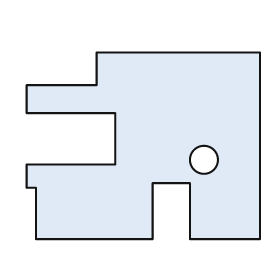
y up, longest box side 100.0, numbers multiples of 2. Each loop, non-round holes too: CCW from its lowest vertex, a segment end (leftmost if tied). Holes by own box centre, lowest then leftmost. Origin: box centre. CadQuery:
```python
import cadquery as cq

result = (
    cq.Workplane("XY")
    .moveTo(-46.0, -40.0)
    .lineTo(4.0, -40.0)
    .lineTo(4.0, -16.0)
    .lineTo(20.0, -16.0)
    .lineTo(20.0, -40.0)
    .lineTo(50.0, -40.0)
    .lineTo(50.0, 40.0)
    .lineTo(-20.0, 40.0)
    .lineTo(-20.0, 26.0)
    .lineTo(-50.0, 26.0)
    .lineTo(-50.0, 14.0)
    .lineTo(-12.0, 14.0)
    .lineTo(-12.0, -8.0)
    .lineTo(-50.0, -8.0)
    .lineTo(-50.0, -18.0)
    .lineTo(-46.0, -18.0)
    .close()
    .moveTo(26.0, -6.0)
    .circle(6.0)
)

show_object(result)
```